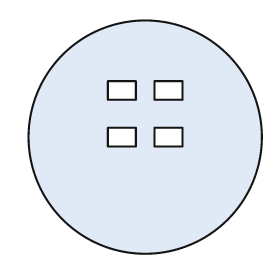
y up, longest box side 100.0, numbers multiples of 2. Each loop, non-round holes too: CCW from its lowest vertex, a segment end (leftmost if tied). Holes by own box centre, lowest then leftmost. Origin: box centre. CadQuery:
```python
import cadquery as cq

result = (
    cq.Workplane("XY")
    .moveTo(0.0, 0.0)
    .circle(50.0)
    .moveTo(-16.0, -4.0)
    .lineTo(-4.0, -4.0)
    .lineTo(-4.0, 4.0)
    .lineTo(-16.0, 4.0)
    .close()
    .moveTo(4.0, -4.0)
    .lineTo(16.0, -4.0)
    .lineTo(16.0, 4.0)
    .lineTo(4.0, 4.0)
    .close()
    .moveTo(-16.0, 16.0)
    .lineTo(-4.0, 16.0)
    .lineTo(-4.0, 24.0)
    .lineTo(-16.0, 24.0)
    .close()
    .moveTo(4.0, 16.0)
    .lineTo(16.0, 16.0)
    .lineTo(16.0, 24.0)
    .lineTo(4.0, 24.0)
    .close()
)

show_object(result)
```